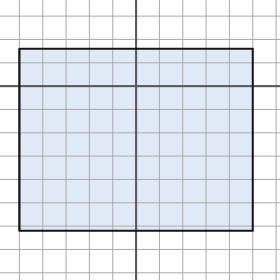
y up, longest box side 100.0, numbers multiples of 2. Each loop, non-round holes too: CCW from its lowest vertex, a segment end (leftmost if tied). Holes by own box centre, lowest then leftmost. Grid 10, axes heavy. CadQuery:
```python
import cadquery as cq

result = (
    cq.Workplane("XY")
    .moveTo(-50.0, -62.0)
    .lineTo(50.0, -62.0)
    .lineTo(50.0, 16.0)
    .lineTo(-50.0, 16.0)
    .close()
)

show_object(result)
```